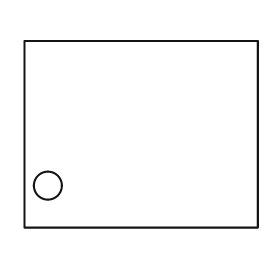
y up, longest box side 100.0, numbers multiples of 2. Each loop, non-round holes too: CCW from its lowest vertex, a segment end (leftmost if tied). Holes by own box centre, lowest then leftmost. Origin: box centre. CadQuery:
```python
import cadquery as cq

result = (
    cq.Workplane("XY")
    .moveTo(-50.0, -40.0)
    .lineTo(50.0, -40.0)
    .lineTo(50.0, 40.0)
    .lineTo(-50.0, 40.0)
    .close()
    .moveTo(-40.0, -22.0)
    .circle(6.0)
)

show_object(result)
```